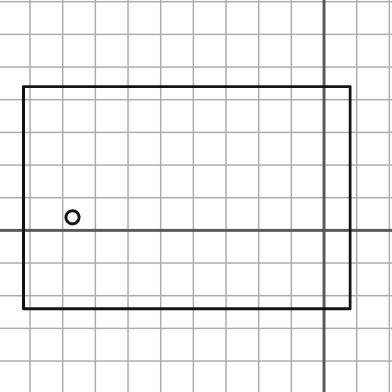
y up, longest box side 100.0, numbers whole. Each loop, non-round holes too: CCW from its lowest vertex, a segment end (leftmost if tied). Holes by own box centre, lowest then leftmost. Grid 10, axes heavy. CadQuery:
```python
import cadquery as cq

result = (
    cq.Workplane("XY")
    .moveTo(-92.0, -24.0)
    .lineTo(8.0, -24.0)
    .lineTo(8.0, 44.0)
    .lineTo(-92.0, 44.0)
    .close()
    .moveTo(-77.0, 4.0)
    .circle(2.0)
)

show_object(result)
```